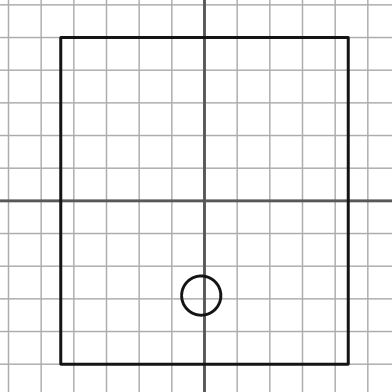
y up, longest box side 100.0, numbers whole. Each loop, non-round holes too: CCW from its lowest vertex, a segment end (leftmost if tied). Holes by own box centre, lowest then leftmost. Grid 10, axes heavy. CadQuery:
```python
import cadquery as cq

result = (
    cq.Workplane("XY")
    .moveTo(-44.0, -50.0)
    .lineTo(44.0, -50.0)
    .lineTo(44.0, 50.0)
    .lineTo(-44.0, 50.0)
    .close()
    .moveTo(-1.0, -29.0)
    .circle(6.0)
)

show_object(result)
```